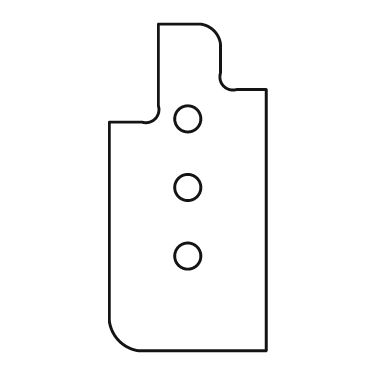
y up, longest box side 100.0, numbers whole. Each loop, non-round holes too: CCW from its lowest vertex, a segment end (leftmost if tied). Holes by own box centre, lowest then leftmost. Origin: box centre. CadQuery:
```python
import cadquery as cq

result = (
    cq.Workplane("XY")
    .moveTo(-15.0, -50.0)
    .lineTo(24.0, -50.0)
    .lineTo(24.0, 30.0)
    .lineTo(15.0, 30.0)
    .threePointArc((11.0, 31.0), (10.0, 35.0))
    .lineTo(10.0, 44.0)
    .threePointArc((8.0, 48.0), (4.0, 50.0))
    .lineTo(-9.0, 50.0)
    .lineTo(-9.0, 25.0)
    .threePointArc((-10.0, 21.0), (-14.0, 20.0))
    .lineTo(-24.0, 20.0)
    .lineTo(-24.0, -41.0)
    .threePointArc((-21.0, -47.0), (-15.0, -50.0))
    .close()
    .moveTo(0.0, -21.0)
    .circle(4.0)
    .moveTo(0.0, 0.0)
    .circle(4.0)
    .moveTo(0.0, 21.0)
    .circle(4.0)
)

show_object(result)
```